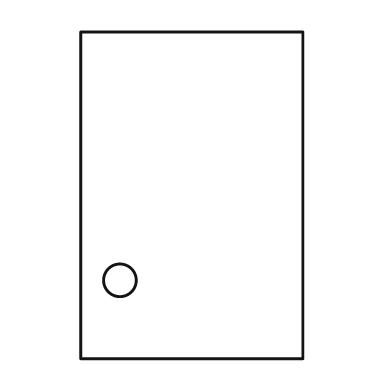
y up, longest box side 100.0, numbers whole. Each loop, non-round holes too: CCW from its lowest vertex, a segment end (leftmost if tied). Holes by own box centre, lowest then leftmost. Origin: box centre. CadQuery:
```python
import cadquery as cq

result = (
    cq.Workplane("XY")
    .moveTo(-34.0, -50.0)
    .lineTo(34.0, -50.0)
    .lineTo(34.0, 50.0)
    .lineTo(-34.0, 50.0)
    .close()
    .moveTo(-22.0, -26.0)
    .circle(5.0)
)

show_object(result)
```